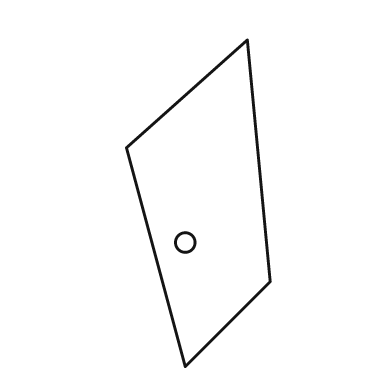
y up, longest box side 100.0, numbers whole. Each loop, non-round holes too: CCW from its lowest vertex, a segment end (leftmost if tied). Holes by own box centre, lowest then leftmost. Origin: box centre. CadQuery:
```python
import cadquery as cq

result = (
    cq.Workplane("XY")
    .moveTo(-4.0, -50.0)
    .lineTo(22.0, -24.0)
    .lineTo(15.0, 50.0)
    .lineTo(-22.0, 17.0)
    .close()
    .moveTo(-4.0, -12.0)
    .circle(3.0)
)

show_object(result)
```